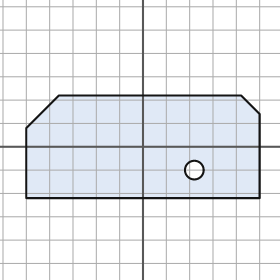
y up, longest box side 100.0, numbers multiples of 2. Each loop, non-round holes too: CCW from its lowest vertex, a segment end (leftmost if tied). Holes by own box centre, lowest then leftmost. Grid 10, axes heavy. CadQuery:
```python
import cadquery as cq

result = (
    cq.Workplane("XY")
    .moveTo(-50.0, -22.0)
    .lineTo(50.0, -22.0)
    .lineTo(50.0, 14.0)
    .lineTo(42.0, 22.0)
    .lineTo(-36.0, 22.0)
    .lineTo(-50.0, 8.0)
    .close()
    .moveTo(22.0, -10.0)
    .circle(4.0)
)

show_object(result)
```